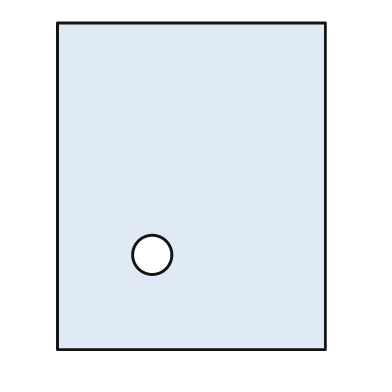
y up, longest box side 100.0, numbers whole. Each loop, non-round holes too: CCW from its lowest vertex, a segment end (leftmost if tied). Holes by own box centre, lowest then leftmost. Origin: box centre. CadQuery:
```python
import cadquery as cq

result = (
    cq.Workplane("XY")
    .moveTo(-41.0, -50.0)
    .lineTo(41.0, -50.0)
    .lineTo(41.0, 50.0)
    .lineTo(-41.0, 50.0)
    .close()
    .moveTo(-12.0, -21.0)
    .circle(6.0)
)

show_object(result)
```